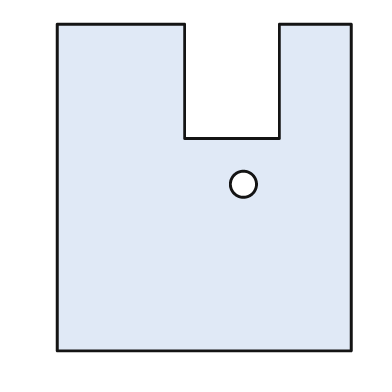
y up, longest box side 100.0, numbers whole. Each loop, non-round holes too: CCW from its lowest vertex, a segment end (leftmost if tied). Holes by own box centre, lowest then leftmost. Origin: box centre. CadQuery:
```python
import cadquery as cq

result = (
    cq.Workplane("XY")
    .moveTo(-45.0, -50.0)
    .lineTo(45.0, -50.0)
    .lineTo(45.0, 50.0)
    .lineTo(23.0, 50.0)
    .lineTo(23.0, 15.0)
    .lineTo(-6.0, 15.0)
    .lineTo(-6.0, 50.0)
    .lineTo(-45.0, 50.0)
    .close()
    .moveTo(12.0, 1.0)
    .circle(4.0)
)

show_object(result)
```